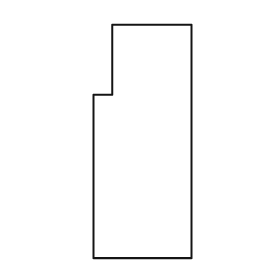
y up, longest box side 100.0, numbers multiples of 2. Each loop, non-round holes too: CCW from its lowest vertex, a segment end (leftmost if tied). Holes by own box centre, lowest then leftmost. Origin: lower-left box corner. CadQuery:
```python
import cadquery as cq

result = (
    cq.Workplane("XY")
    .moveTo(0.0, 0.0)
    .lineTo(42.0, 0.0)
    .lineTo(42.0, 100.0)
    .lineTo(8.0, 100.0)
    .lineTo(8.0, 70.0)
    .lineTo(0.0, 70.0)
    .close()
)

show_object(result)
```